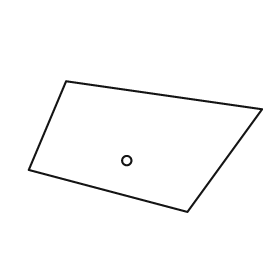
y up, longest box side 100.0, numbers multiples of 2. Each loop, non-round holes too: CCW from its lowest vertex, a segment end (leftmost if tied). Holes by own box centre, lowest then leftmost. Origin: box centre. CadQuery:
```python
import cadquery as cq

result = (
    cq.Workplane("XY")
    .moveTo(18.0, -28.0)
    .lineTo(50.0, 16.0)
    .lineTo(-34.0, 28.0)
    .lineTo(-50.0, -10.0)
    .close()
    .moveTo(-8.0, -6.0)
    .circle(2.0)
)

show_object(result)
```